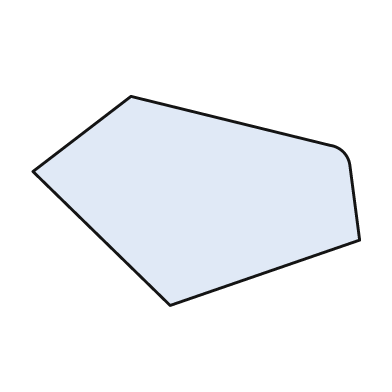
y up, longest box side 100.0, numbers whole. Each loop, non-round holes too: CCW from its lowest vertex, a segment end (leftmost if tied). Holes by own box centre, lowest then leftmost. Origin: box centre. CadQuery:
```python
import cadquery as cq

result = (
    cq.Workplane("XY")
    .moveTo(-8.0, -32.0)
    .lineTo(50.0, -12.0)
    .lineTo(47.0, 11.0)
    .threePointArc((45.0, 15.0), (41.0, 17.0))
    .lineTo(-20.0, 32.0)
    .lineTo(-50.0, 9.0)
    .close()
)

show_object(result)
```